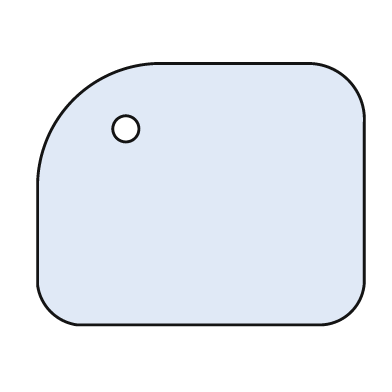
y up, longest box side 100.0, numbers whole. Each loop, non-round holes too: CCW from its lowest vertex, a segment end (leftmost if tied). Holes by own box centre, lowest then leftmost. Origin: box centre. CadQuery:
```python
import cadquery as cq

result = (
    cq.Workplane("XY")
    .moveTo(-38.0, -40.0)
    .lineTo(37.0, -40.0)
    .threePointArc((46.0, -36.0), (50.0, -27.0))
    .lineTo(50.0, 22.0)
    .threePointArc((45.0, 35.0), (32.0, 40.0))
    .lineTo(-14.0, 40.0)
    .threePointArc((-39.0, 29.0), (-50.0, 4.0))
    .lineTo(-50.0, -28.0)
    .threePointArc((-46.0, -36.0), (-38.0, -40.0))
    .close()
    .moveTo(-23.0, 20.0)
    .circle(4.0)
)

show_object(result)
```